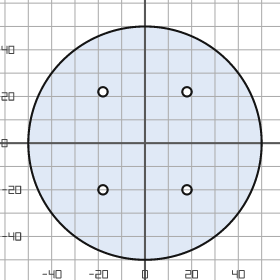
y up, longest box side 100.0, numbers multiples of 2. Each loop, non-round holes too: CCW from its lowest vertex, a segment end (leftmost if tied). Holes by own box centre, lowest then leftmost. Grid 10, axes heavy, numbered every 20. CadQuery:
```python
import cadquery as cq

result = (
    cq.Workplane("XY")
    .moveTo(0.0, 0.0)
    .circle(50.0)
    .moveTo(-18.0, -20.0)
    .circle(2.0)
    .moveTo(18.0, -20.0)
    .circle(2.0)
    .moveTo(-18.0, 22.0)
    .circle(2.0)
    .moveTo(18.0, 22.0)
    .circle(2.0)
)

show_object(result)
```